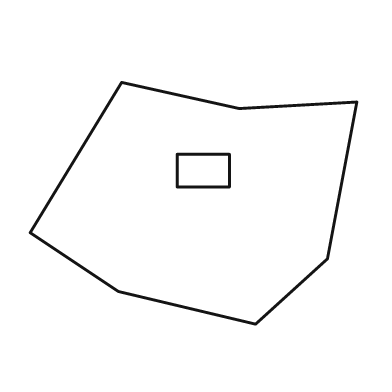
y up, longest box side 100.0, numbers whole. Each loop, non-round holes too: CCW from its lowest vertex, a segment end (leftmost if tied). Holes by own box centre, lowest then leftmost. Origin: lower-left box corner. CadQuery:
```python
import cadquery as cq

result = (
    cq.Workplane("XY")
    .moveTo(69.0, 0.0)
    .lineTo(91.0, 20.0)
    .lineTo(100.0, 68.0)
    .lineTo(64.0, 66.0)
    .lineTo(28.0, 74.0)
    .lineTo(0.0, 28.0)
    .lineTo(27.0, 10.0)
    .close()
    .moveTo(45.0, 42.0)
    .lineTo(61.0, 42.0)
    .lineTo(61.0, 52.0)
    .lineTo(45.0, 52.0)
    .close()
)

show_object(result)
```